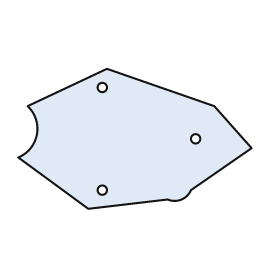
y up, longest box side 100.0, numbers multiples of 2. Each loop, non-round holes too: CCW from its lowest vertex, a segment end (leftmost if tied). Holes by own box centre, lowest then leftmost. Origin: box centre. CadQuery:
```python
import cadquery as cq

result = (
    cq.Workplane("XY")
    .moveTo(-20.0, -30.0)
    .lineTo(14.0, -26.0)
    .threePointArc((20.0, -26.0), (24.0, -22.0))
    .lineTo(50.0, -4.0)
    .lineTo(34.0, 14.0)
    .lineTo(-12.0, 30.0)
    .lineTo(-46.0, 14.0)
    .threePointArc((-42.0, 2.0), (-50.0, -8.0))
    .close()
    .moveTo(-14.0, -22.0)
    .circle(2.0)
    .moveTo(26.0, 0.0)
    .circle(2.0)
    .moveTo(-14.0, 22.0)
    .circle(2.0)
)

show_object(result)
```